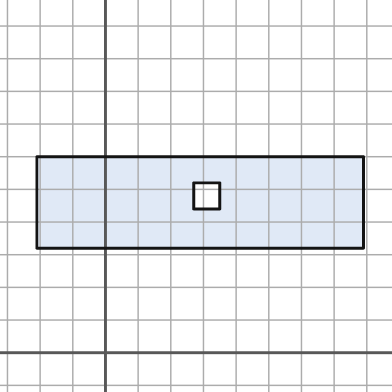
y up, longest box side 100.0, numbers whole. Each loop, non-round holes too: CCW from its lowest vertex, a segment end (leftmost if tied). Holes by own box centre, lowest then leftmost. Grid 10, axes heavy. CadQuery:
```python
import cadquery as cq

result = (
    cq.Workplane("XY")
    .moveTo(-21.0, 32.0)
    .lineTo(79.0, 32.0)
    .lineTo(79.0, 60.0)
    .lineTo(-21.0, 60.0)
    .close()
    .moveTo(27.0, 44.0)
    .lineTo(35.0, 44.0)
    .lineTo(35.0, 52.0)
    .lineTo(27.0, 52.0)
    .close()
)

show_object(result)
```